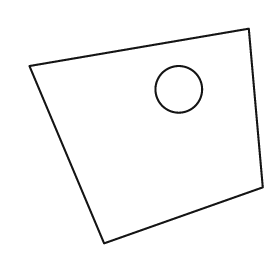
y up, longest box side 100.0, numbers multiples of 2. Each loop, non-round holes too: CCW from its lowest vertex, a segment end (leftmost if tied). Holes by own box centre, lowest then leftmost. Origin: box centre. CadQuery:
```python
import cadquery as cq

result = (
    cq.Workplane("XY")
    .moveTo(-18.0, -46.0)
    .lineTo(50.0, -22.0)
    .lineTo(44.0, 46.0)
    .lineTo(-50.0, 30.0)
    .close()
    .moveTo(14.0, 20.0)
    .circle(10.0)
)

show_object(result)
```